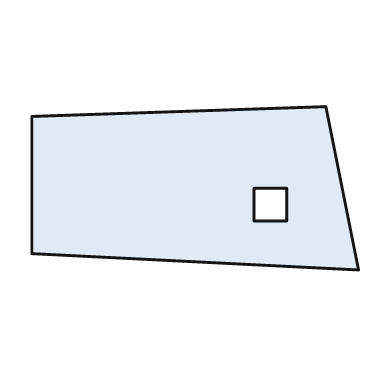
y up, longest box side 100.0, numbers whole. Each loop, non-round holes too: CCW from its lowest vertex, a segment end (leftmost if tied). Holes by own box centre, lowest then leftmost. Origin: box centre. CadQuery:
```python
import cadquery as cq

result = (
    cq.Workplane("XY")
    .moveTo(50.0, -25.0)
    .lineTo(40.0, 25.0)
    .lineTo(-50.0, 22.0)
    .lineTo(-50.0, -20.0)
    .close()
    .moveTo(18.0, -10.0)
    .lineTo(28.0, -10.0)
    .lineTo(28.0, 0.0)
    .lineTo(18.0, 0.0)
    .close()
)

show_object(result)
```